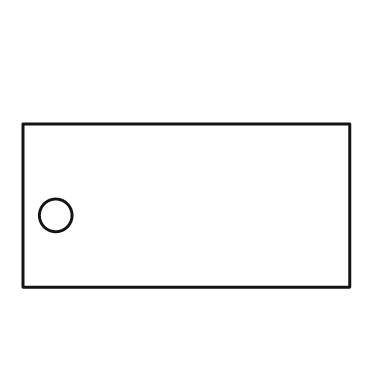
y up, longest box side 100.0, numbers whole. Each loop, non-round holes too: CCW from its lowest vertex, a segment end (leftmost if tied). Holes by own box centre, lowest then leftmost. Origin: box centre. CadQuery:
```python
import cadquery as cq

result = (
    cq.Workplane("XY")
    .moveTo(-50.0, -25.0)
    .lineTo(50.0, -25.0)
    .lineTo(50.0, 25.0)
    .lineTo(-50.0, 25.0)
    .close()
    .moveTo(-40.0, -3.0)
    .circle(5.0)
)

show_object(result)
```